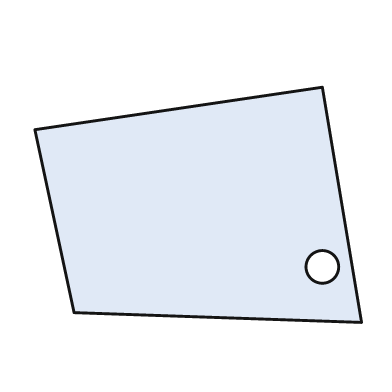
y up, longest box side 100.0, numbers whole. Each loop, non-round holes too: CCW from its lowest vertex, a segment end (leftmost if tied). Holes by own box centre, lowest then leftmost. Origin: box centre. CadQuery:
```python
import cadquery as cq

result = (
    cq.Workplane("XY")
    .moveTo(50.0, -36.0)
    .lineTo(38.0, 36.0)
    .lineTo(-50.0, 23.0)
    .lineTo(-38.0, -33.0)
    .close()
    .moveTo(38.0, -19.0)
    .circle(5.0)
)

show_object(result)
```